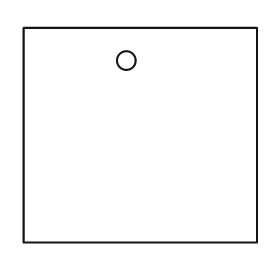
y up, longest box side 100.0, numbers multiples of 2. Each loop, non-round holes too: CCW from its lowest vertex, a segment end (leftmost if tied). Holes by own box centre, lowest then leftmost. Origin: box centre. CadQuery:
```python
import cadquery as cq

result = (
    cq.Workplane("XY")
    .moveTo(-50.0, -46.0)
    .lineTo(50.0, -46.0)
    .lineTo(50.0, 46.0)
    .lineTo(-50.0, 46.0)
    .close()
    .moveTo(-6.0, 32.0)
    .circle(4.0)
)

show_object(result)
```